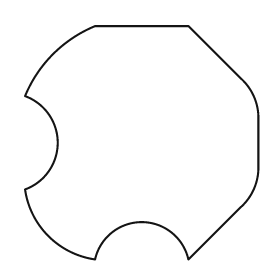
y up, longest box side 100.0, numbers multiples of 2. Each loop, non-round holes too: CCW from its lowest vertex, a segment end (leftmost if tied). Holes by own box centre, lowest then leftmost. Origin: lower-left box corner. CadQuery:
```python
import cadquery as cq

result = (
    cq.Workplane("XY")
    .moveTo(30.0, 0.0)
    .threePointArc((50.0, 16.0), (70.0, 0.0))
    .lineTo(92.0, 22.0)
    .threePointArc((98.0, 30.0), (100.0, 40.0))
    .lineTo(100.0, 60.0)
    .threePointArc((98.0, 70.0), (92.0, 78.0))
    .lineTo(70.0, 100.0)
    .lineTo(30.0, 100.0)
    .threePointArc((12.0, 88.0), (0.0, 70.0))
    .threePointArc((14.0, 50.0), (0.0, 30.0))
    .threePointArc((10.0, 10.0), (30.0, 0.0))
    .close()
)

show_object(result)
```